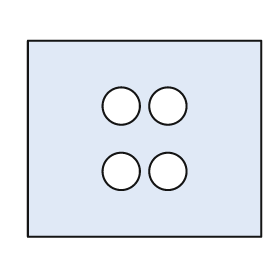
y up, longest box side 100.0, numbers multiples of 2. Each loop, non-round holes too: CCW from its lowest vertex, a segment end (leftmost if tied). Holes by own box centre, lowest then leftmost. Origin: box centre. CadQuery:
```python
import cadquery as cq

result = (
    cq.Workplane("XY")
    .moveTo(-50.0, -42.0)
    .lineTo(50.0, -42.0)
    .lineTo(50.0, 42.0)
    .lineTo(-50.0, 42.0)
    .close()
    .moveTo(-10.0, -14.0)
    .circle(8.0)
    .moveTo(10.0, -14.0)
    .circle(8.0)
    .moveTo(-10.0, 14.0)
    .circle(8.0)
    .moveTo(10.0, 14.0)
    .circle(8.0)
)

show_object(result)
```